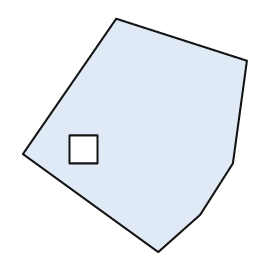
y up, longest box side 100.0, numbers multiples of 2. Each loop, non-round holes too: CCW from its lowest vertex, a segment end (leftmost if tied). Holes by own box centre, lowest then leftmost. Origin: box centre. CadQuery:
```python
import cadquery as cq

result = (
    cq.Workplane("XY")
    .moveTo(10.0, -50.0)
    .lineTo(28.0, -34.0)
    .lineTo(42.0, -12.0)
    .lineTo(48.0, 32.0)
    .lineTo(-8.0, 50.0)
    .lineTo(-48.0, -8.0)
    .close()
    .moveTo(-28.0, -12.0)
    .lineTo(-16.0, -12.0)
    .lineTo(-16.0, 0.0)
    .lineTo(-28.0, 0.0)
    .close()
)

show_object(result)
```